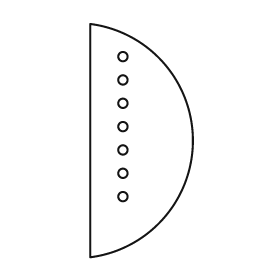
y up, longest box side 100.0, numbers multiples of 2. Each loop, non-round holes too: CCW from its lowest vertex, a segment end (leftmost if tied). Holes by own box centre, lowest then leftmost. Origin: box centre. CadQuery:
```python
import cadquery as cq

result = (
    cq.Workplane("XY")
    .moveTo(-22.0, -50.0)
    .threePointArc((22.0, 0.0), (-22.0, 50.0))
    .close()
    .moveTo(-8.0, -24.0)
    .circle(2.0)
    .moveTo(-8.0, -14.0)
    .circle(2.0)
    .moveTo(-8.0, -4.0)
    .circle(2.0)
    .moveTo(-8.0, 6.0)
    .circle(2.0)
    .moveTo(-8.0, 16.0)
    .circle(2.0)
    .moveTo(-8.0, 26.0)
    .circle(2.0)
    .moveTo(-8.0, 36.0)
    .circle(2.0)
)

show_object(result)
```